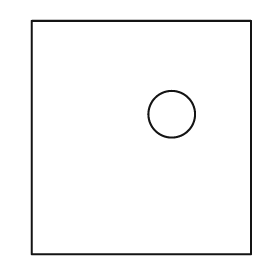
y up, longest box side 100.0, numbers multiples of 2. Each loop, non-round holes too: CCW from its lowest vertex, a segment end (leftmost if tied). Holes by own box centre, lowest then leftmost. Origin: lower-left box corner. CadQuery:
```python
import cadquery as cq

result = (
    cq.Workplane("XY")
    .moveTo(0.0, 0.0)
    .lineTo(94.0, 0.0)
    .lineTo(94.0, 100.0)
    .lineTo(0.0, 100.0)
    .close()
    .moveTo(60.0, 60.0)
    .circle(10.0)
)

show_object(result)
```